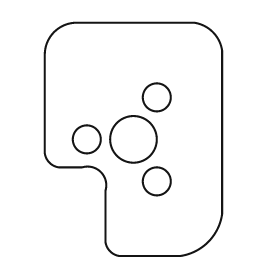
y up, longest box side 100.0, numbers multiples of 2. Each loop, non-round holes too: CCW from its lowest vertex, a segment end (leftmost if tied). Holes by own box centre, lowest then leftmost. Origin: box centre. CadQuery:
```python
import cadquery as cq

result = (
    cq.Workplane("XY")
    .moveTo(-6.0, -50.0)
    .lineTo(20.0, -50.0)
    .threePointArc((32.0, -44.0), (38.0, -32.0))
    .lineTo(38.0, 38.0)
    .threePointArc((34.0, 46.0), (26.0, 50.0))
    .lineTo(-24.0, 50.0)
    .threePointArc((-34.0, 46.0), (-38.0, 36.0))
    .lineTo(-38.0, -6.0)
    .threePointArc((-36.0, -10.0), (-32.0, -12.0))
    .lineTo(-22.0, -12.0)
    .threePointArc((-14.0, -14.0), (-12.0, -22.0))
    .lineTo(-12.0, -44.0)
    .threePointArc((-10.0, -48.0), (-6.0, -50.0))
    .close()
    .moveTo(10.0, -18.0)
    .circle(6.0)
    .moveTo(-20.0, 0.0)
    .circle(6.0)
    .moveTo(0.0, 0.0)
    .circle(10.0)
    .moveTo(10.0, 18.0)
    .circle(6.0)
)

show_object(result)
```